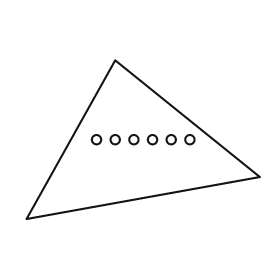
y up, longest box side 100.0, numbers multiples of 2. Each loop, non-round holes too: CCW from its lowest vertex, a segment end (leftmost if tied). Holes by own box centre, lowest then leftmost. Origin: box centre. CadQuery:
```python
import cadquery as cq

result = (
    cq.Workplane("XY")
    .moveTo(-50.0, -34.0)
    .lineTo(50.0, -16.0)
    .lineTo(-12.0, 34.0)
    .close()
    .moveTo(-20.0, 0.0)
    .circle(2.0)
    .moveTo(-12.0, 0.0)
    .circle(2.0)
    .moveTo(-4.0, 0.0)
    .circle(2.0)
    .moveTo(4.0, 0.0)
    .circle(2.0)
    .moveTo(12.0, 0.0)
    .circle(2.0)
    .moveTo(20.0, 0.0)
    .circle(2.0)
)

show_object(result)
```